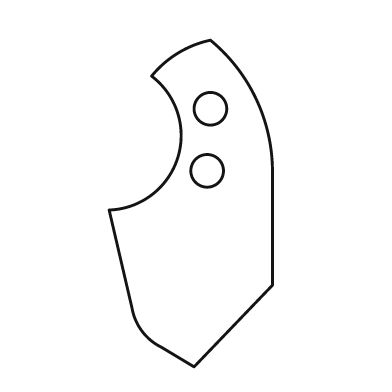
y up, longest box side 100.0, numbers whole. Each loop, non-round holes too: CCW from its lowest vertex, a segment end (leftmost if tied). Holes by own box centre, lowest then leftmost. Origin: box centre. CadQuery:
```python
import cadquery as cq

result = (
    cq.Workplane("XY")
    .moveTo(1.0, -50.0)
    .lineTo(25.0, -25.0)
    .lineTo(25.0, 10.0)
    .threePointArc((20.0, 32.0), (6.0, 50.0))
    .threePointArc((-4.0, 46.0), (-12.0, 39.0))
    .threePointArc((-4.0, 14.0), (-25.0, -2.0))
    .lineTo(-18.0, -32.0)
    .threePointArc((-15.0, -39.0), (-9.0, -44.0))
    .close()
    .moveTo(5.0, 10.0)
    .circle(5.0)
    .moveTo(6.0, 29.0)
    .circle(5.0)
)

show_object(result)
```